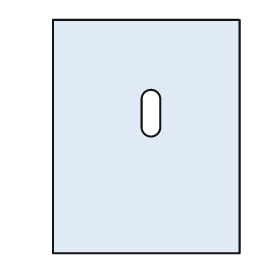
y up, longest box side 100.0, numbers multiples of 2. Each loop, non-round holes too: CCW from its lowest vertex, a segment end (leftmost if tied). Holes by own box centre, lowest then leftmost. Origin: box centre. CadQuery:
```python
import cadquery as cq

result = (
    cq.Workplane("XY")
    .moveTo(-40.0, -50.0)
    .lineTo(40.0, -50.0)
    .lineTo(40.0, 50.0)
    .lineTo(-40.0, 50.0)
    .close()
    .moveTo(-2.0, 4.0)
    .threePointArc((2.0, 0.0), (6.0, 4.0))
    .lineTo(6.0, 16.0)
    .threePointArc((2.0, 20.0), (-2.0, 16.0))
    .close()
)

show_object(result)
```